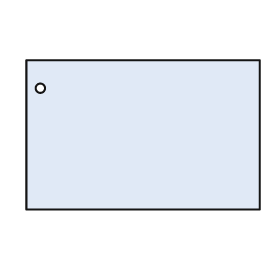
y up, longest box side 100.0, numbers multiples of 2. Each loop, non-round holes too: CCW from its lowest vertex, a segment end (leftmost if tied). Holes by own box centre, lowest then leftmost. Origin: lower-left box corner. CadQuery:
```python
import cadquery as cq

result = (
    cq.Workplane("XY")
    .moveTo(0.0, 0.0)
    .lineTo(100.0, 0.0)
    .lineTo(100.0, 64.0)
    .lineTo(0.0, 64.0)
    .close()
    .moveTo(6.0, 52.0)
    .circle(2.0)
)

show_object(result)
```